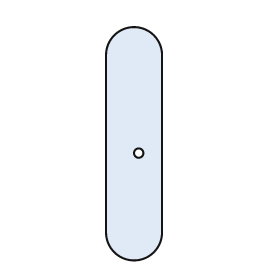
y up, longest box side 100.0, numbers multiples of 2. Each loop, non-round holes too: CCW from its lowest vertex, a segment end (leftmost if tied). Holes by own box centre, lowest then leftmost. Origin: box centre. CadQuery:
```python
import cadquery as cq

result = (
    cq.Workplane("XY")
    .moveTo(-12.0, -38.0)
    .threePointArc((0.0, -50.0), (12.0, -38.0))
    .lineTo(12.0, 38.0)
    .threePointArc((0.0, 50.0), (-12.0, 38.0))
    .close()
    .moveTo(2.0, -4.0)
    .circle(2.0)
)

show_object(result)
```